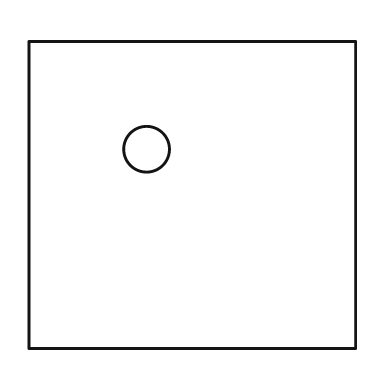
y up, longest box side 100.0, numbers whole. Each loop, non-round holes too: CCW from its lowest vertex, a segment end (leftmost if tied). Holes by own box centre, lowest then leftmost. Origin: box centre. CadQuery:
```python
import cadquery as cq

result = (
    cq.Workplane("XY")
    .moveTo(-50.0, -47.0)
    .lineTo(50.0, -47.0)
    .lineTo(50.0, 47.0)
    .lineTo(-50.0, 47.0)
    .close()
    .moveTo(-14.0, 14.0)
    .circle(7.0)
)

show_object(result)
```